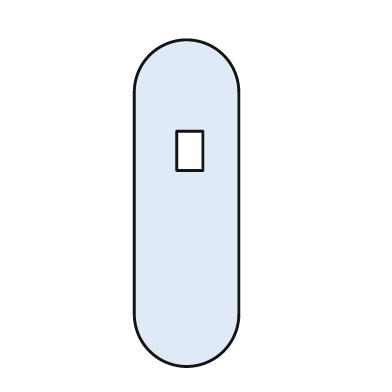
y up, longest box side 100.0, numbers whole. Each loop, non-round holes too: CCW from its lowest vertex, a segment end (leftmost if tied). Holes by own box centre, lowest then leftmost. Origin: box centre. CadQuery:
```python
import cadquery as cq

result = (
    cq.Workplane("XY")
    .moveTo(-16.0, -34.0)
    .threePointArc((0.0, -50.0), (16.0, -34.0))
    .lineTo(16.0, 34.0)
    .threePointArc((0.0, 50.0), (-16.0, 34.0))
    .close()
    .moveTo(-3.0, 10.0)
    .lineTo(5.0, 10.0)
    .lineTo(5.0, 22.0)
    .lineTo(-3.0, 22.0)
    .close()
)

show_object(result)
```